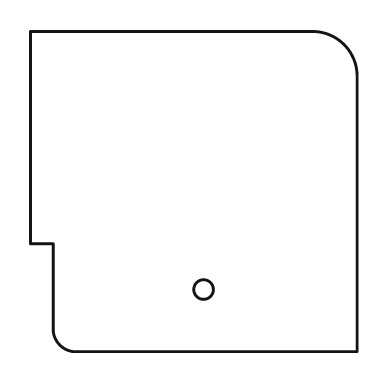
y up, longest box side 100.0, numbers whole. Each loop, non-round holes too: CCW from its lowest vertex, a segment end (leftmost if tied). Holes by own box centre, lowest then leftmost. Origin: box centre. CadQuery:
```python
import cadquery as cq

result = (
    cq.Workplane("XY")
    .moveTo(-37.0, -49.0)
    .lineTo(50.0, -49.0)
    .lineTo(50.0, 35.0)
    .threePointArc((46.0, 45.0), (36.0, 49.0))
    .lineTo(-50.0, 49.0)
    .lineTo(-50.0, -16.0)
    .lineTo(-43.0, -16.0)
    .lineTo(-43.0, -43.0)
    .threePointArc((-41.0, -47.0), (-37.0, -49.0))
    .close()
    .moveTo(3.0, -30.0)
    .circle(3.0)
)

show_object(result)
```